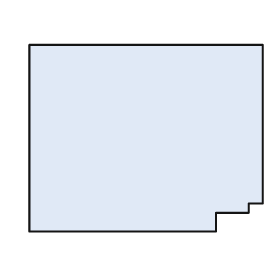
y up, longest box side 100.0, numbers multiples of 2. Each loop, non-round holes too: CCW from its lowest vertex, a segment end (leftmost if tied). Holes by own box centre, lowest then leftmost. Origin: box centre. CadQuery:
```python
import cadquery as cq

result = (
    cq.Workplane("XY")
    .moveTo(-50.0, -40.0)
    .lineTo(30.0, -40.0)
    .lineTo(30.0, -32.0)
    .lineTo(44.0, -32.0)
    .lineTo(44.0, -28.0)
    .lineTo(50.0, -28.0)
    .lineTo(50.0, 40.0)
    .lineTo(-50.0, 40.0)
    .close()
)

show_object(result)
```